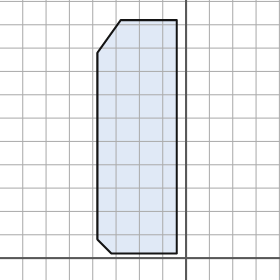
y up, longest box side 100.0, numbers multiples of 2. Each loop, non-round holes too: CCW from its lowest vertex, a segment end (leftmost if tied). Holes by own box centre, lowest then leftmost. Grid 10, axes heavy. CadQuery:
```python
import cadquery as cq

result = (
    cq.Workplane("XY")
    .moveTo(-32.0, 2.0)
    .lineTo(-4.0, 2.0)
    .lineTo(-4.0, 102.0)
    .lineTo(-28.0, 102.0)
    .lineTo(-38.0, 88.0)
    .lineTo(-38.0, 8.0)
    .close()
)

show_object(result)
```